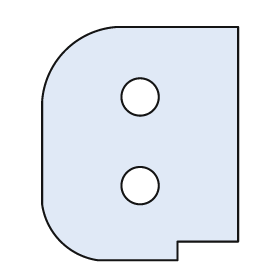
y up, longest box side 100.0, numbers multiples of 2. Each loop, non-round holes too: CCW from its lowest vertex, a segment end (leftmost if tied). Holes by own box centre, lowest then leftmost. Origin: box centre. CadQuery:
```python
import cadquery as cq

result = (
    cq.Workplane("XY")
    .moveTo(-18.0, -50.0)
    .lineTo(16.0, -50.0)
    .lineTo(16.0, -42.0)
    .lineTo(42.0, -42.0)
    .lineTo(42.0, 50.0)
    .lineTo(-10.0, 50.0)
    .threePointArc((-32.0, 40.0), (-42.0, 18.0))
    .lineTo(-42.0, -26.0)
    .threePointArc((-34.0, -42.0), (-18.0, -50.0))
    .close()
    .moveTo(0.0, -18.0)
    .circle(8.0)
    .moveTo(0.0, 20.0)
    .circle(8.0)
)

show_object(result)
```